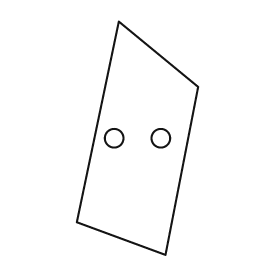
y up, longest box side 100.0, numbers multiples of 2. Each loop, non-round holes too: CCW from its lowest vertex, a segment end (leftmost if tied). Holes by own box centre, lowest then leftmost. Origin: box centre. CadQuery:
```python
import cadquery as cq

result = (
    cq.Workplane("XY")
    .moveTo(12.0, -50.0)
    .lineTo(26.0, 22.0)
    .lineTo(-8.0, 50.0)
    .lineTo(-26.0, -36.0)
    .close()
    .moveTo(-10.0, 0.0)
    .circle(4.0)
    .moveTo(10.0, 0.0)
    .circle(4.0)
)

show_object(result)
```